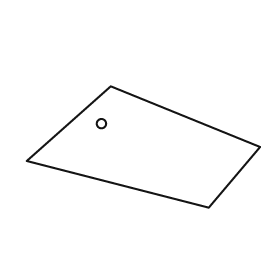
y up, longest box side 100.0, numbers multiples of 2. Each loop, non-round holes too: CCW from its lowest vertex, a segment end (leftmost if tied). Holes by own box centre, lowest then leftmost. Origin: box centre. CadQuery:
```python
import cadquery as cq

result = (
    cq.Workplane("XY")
    .moveTo(28.0, -26.0)
    .lineTo(50.0, 0.0)
    .lineTo(-14.0, 26.0)
    .lineTo(-50.0, -6.0)
    .close()
    .moveTo(-18.0, 10.0)
    .circle(2.0)
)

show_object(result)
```